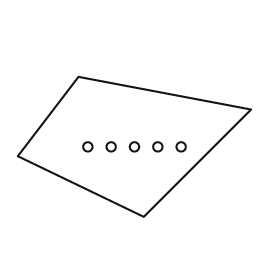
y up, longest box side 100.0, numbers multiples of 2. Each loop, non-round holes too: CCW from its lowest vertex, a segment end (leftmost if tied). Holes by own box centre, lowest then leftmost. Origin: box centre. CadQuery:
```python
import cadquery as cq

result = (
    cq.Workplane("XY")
    .moveTo(4.0, -30.0)
    .lineTo(50.0, 16.0)
    .lineTo(-24.0, 30.0)
    .lineTo(-50.0, -4.0)
    .close()
    .moveTo(-20.0, 0.0)
    .circle(2.0)
    .moveTo(-10.0, 0.0)
    .circle(2.0)
    .moveTo(0.0, 0.0)
    .circle(2.0)
    .moveTo(10.0, 0.0)
    .circle(2.0)
    .moveTo(20.0, 0.0)
    .circle(2.0)
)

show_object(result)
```